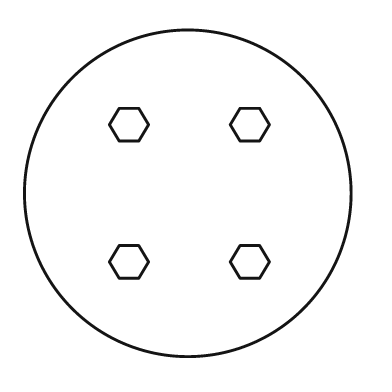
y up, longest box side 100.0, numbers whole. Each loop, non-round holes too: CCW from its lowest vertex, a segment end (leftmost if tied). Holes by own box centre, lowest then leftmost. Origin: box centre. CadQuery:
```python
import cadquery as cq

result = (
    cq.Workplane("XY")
    .moveTo(0.0, 0.0)
    .circle(50.0)
    .moveTo(-21.0, -26.0)
    .lineTo(-15.0, -26.0)
    .lineTo(-12.0, -21.0)
    .lineTo(-15.0, -16.0)
    .lineTo(-21.0, -16.0)
    .lineTo(-24.0, -21.0)
    .close()
    .moveTo(16.0, -26.0)
    .lineTo(22.0, -26.0)
    .lineTo(25.0, -21.0)
    .lineTo(22.0, -16.0)
    .lineTo(16.0, -16.0)
    .lineTo(13.0, -21.0)
    .close()
    .moveTo(-21.0, 16.0)
    .lineTo(-15.0, 16.0)
    .lineTo(-12.0, 21.0)
    .lineTo(-15.0, 26.0)
    .lineTo(-21.0, 26.0)
    .lineTo(-24.0, 21.0)
    .close()
    .moveTo(16.0, 16.0)
    .lineTo(22.0, 16.0)
    .lineTo(25.0, 21.0)
    .lineTo(22.0, 26.0)
    .lineTo(16.0, 26.0)
    .lineTo(13.0, 21.0)
    .close()
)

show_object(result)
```